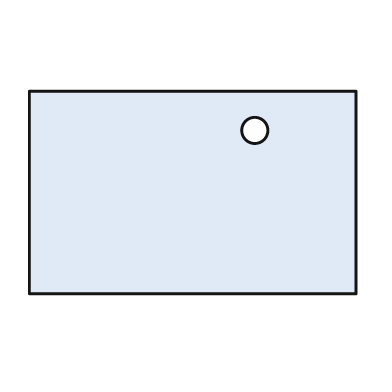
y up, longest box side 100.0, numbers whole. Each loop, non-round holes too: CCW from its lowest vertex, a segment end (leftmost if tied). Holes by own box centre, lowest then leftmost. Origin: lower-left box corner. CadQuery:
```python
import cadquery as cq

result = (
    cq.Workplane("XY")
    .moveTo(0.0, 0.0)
    .lineTo(100.0, 0.0)
    .lineTo(100.0, 62.0)
    .lineTo(0.0, 62.0)
    .close()
    .moveTo(69.0, 50.0)
    .circle(4.0)
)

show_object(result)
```